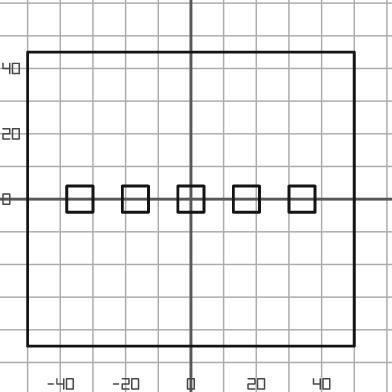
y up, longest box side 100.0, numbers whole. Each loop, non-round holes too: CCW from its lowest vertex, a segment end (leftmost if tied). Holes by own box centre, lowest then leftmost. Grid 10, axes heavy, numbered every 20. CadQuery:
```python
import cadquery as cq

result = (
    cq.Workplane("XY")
    .moveTo(-50.0, -45.0)
    .lineTo(50.0, -45.0)
    .lineTo(50.0, 45.0)
    .lineTo(-50.0, 45.0)
    .close()
    .moveTo(-38.0, -4.0)
    .lineTo(-30.0, -4.0)
    .lineTo(-30.0, 4.0)
    .lineTo(-38.0, 4.0)
    .close()
    .moveTo(-21.0, -4.0)
    .lineTo(-13.0, -4.0)
    .lineTo(-13.0, 4.0)
    .lineTo(-21.0, 4.0)
    .close()
    .moveTo(-4.0, -4.0)
    .lineTo(4.0, -4.0)
    .lineTo(4.0, 4.0)
    .lineTo(-4.0, 4.0)
    .close()
    .moveTo(13.0, -4.0)
    .lineTo(21.0, -4.0)
    .lineTo(21.0, 4.0)
    .lineTo(13.0, 4.0)
    .close()
    .moveTo(30.0, -4.0)
    .lineTo(38.0, -4.0)
    .lineTo(38.0, 4.0)
    .lineTo(30.0, 4.0)
    .close()
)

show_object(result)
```